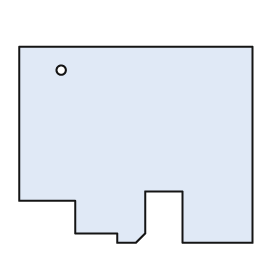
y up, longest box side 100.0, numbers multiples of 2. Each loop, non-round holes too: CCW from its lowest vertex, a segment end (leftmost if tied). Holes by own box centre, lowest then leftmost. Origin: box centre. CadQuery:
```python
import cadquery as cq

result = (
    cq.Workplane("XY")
    .moveTo(-8.0, -42.0)
    .lineTo(0.0, -42.0)
    .lineTo(4.0, -38.0)
    .lineTo(4.0, -20.0)
    .lineTo(20.0, -20.0)
    .lineTo(20.0, -42.0)
    .lineTo(50.0, -42.0)
    .lineTo(50.0, 42.0)
    .lineTo(-50.0, 42.0)
    .lineTo(-50.0, -24.0)
    .lineTo(-26.0, -24.0)
    .lineTo(-26.0, -38.0)
    .lineTo(-8.0, -38.0)
    .close()
    .moveTo(-32.0, 32.0)
    .circle(2.0)
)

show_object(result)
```